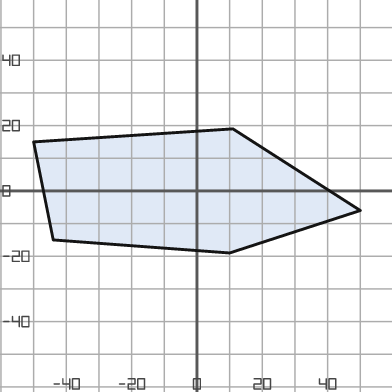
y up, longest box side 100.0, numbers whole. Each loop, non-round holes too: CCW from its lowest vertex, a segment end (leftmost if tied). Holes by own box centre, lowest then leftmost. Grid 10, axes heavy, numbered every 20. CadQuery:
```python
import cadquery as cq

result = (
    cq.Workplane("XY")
    .moveTo(10.0, -19.0)
    .lineTo(50.0, -6.0)
    .lineTo(11.0, 19.0)
    .lineTo(-50.0, 15.0)
    .lineTo(-44.0, -15.0)
    .close()
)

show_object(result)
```